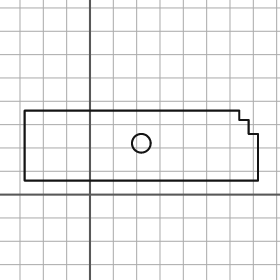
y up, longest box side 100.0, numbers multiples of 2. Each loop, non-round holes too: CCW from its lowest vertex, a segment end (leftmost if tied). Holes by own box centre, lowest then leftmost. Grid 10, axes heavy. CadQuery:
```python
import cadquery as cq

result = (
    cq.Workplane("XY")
    .moveTo(-28.0, 6.0)
    .lineTo(72.0, 6.0)
    .lineTo(72.0, 26.0)
    .lineTo(68.0, 26.0)
    .lineTo(68.0, 32.0)
    .lineTo(64.0, 32.0)
    .lineTo(64.0, 36.0)
    .lineTo(-28.0, 36.0)
    .close()
    .moveTo(22.0, 22.0)
    .circle(4.0)
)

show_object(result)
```